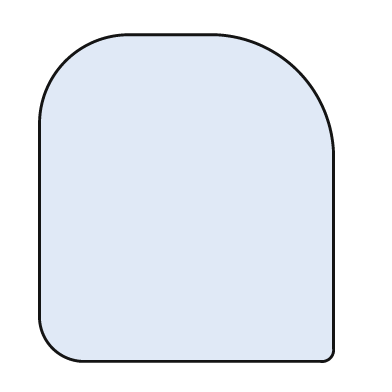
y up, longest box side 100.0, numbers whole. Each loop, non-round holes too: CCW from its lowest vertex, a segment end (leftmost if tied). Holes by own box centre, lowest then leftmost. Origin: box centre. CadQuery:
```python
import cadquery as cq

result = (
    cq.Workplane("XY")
    .moveTo(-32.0, -50.0)
    .lineTo(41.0, -50.0)
    .threePointArc((44.0, -49.0), (45.0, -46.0))
    .lineTo(45.0, 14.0)
    .threePointArc((34.0, 39.0), (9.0, 50.0))
    .lineTo(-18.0, 50.0)
    .threePointArc((-37.0, 42.0), (-45.0, 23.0))
    .lineTo(-45.0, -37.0)
    .threePointArc((-41.0, -46.0), (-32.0, -50.0))
    .close()
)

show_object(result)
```